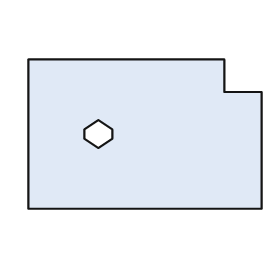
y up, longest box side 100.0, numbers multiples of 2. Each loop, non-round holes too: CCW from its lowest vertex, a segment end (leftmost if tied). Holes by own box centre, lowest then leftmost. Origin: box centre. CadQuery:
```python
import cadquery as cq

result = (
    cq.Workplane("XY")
    .moveTo(-50.0, -32.0)
    .lineTo(50.0, -32.0)
    .lineTo(50.0, 18.0)
    .lineTo(34.0, 18.0)
    .lineTo(34.0, 32.0)
    .lineTo(-50.0, 32.0)
    .close()
    .moveTo(-20.0, -6.0)
    .lineTo(-14.0, -2.0)
    .lineTo(-14.0, 2.0)
    .lineTo(-20.0, 6.0)
    .lineTo(-26.0, 2.0)
    .lineTo(-26.0, -2.0)
    .close()
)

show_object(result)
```